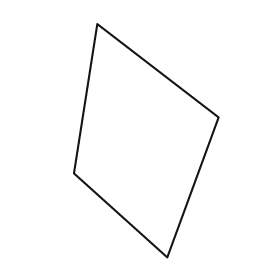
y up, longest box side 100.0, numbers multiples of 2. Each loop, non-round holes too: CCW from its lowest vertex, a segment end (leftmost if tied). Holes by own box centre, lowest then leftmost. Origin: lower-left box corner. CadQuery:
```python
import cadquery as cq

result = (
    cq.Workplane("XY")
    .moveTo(40.0, 0.0)
    .lineTo(62.0, 60.0)
    .lineTo(10.0, 100.0)
    .lineTo(0.0, 36.0)
    .close()
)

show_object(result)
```